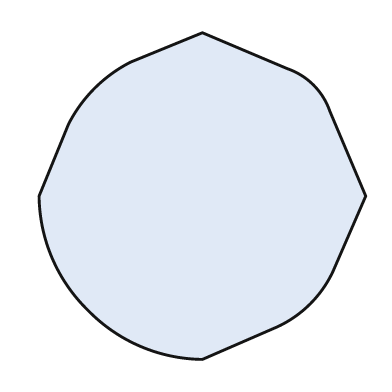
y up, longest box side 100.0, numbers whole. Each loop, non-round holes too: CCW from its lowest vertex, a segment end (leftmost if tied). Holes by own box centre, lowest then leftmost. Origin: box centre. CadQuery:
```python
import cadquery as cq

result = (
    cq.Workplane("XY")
    .moveTo(0.0, -50.0)
    .lineTo(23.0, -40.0)
    .threePointArc((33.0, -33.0), (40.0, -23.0))
    .lineTo(50.0, 0.0)
    .lineTo(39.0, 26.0)
    .threePointArc((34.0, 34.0), (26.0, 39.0))
    .lineTo(0.0, 50.0)
    .lineTo(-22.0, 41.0)
    .threePointArc((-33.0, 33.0), (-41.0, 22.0))
    .lineTo(-50.0, 0.0)
    .threePointArc((-46.0, -19.0), (-35.0, -35.0))
    .threePointArc((-19.0, -46.0), (0.0, -50.0))
    .close()
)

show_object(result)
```